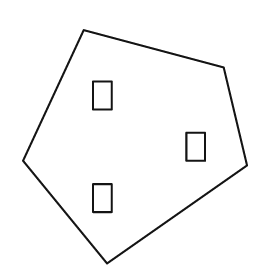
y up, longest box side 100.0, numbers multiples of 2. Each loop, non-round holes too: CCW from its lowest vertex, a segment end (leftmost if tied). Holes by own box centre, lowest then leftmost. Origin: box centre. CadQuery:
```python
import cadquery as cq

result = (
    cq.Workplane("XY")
    .moveTo(-12.0, -50.0)
    .lineTo(48.0, -8.0)
    .lineTo(38.0, 34.0)
    .lineTo(-22.0, 50.0)
    .lineTo(-48.0, -6.0)
    .close()
    .moveTo(-18.0, -28.0)
    .lineTo(-10.0, -28.0)
    .lineTo(-10.0, -16.0)
    .lineTo(-18.0, -16.0)
    .close()
    .moveTo(22.0, -6.0)
    .lineTo(30.0, -6.0)
    .lineTo(30.0, 6.0)
    .lineTo(22.0, 6.0)
    .close()
    .moveTo(-18.0, 16.0)
    .lineTo(-10.0, 16.0)
    .lineTo(-10.0, 28.0)
    .lineTo(-18.0, 28.0)
    .close()
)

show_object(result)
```